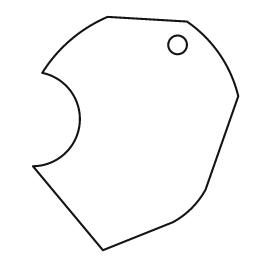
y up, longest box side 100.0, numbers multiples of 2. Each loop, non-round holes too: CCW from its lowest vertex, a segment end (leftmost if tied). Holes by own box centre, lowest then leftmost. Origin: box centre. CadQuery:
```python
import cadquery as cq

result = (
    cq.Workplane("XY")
    .moveTo(-14.0, -50.0)
    .lineTo(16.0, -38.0)
    .threePointArc((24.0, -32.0), (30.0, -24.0))
    .lineTo(44.0, 16.0)
    .threePointArc((36.0, 34.0), (22.0, 48.0))
    .lineTo(-12.0, 50.0)
    .threePointArc((-28.0, 40.0), (-40.0, 26.0))
    .threePointArc((-24.0, 4.0), (-44.0, -14.0))
    .close()
    .moveTo(18.0, 38.0)
    .circle(4.0)
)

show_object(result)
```